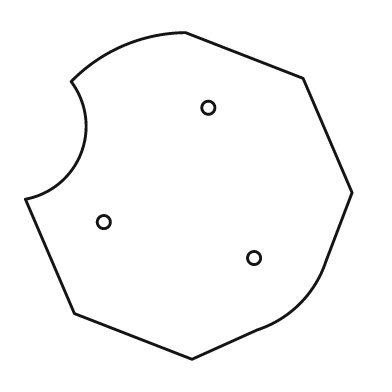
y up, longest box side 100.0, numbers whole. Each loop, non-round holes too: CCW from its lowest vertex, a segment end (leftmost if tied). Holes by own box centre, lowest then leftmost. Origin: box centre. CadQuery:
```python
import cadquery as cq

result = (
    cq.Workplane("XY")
    .moveTo(1.0, -50.0)
    .lineTo(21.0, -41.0)
    .threePointArc((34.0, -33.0), (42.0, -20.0))
    .lineTo(50.0, 1.0)
    .lineTo(35.0, 36.0)
    .lineTo(-1.0, 50.0)
    .threePointArc((-20.0, 46.0), (-36.0, 35.0))
    .threePointArc((-33.0, 13.0), (-50.0, -1.0))
    .lineTo(-35.0, -36.0)
    .close()
    .moveTo(20.0, -19.0)
    .circle(2.0)
    .moveTo(-26.0, -8.0)
    .circle(2.0)
    .moveTo(6.0, 27.0)
    .circle(2.0)
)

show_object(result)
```